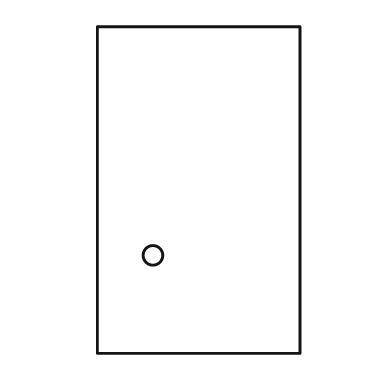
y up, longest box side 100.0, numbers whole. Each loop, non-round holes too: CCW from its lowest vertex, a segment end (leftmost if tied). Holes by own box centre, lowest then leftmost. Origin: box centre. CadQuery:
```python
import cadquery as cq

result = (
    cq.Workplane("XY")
    .moveTo(-31.0, -50.0)
    .lineTo(31.0, -50.0)
    .lineTo(31.0, 50.0)
    .lineTo(-31.0, 50.0)
    .close()
    .moveTo(-14.0, -20.0)
    .circle(3.0)
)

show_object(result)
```